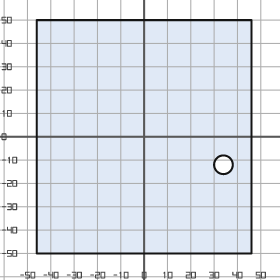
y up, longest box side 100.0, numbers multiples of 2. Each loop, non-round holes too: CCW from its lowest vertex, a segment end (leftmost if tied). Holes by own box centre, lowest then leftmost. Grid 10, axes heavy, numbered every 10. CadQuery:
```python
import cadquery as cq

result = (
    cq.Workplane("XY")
    .moveTo(-46.0, -50.0)
    .lineTo(46.0, -50.0)
    .lineTo(46.0, 50.0)
    .lineTo(-46.0, 50.0)
    .close()
    .moveTo(34.0, -12.0)
    .circle(4.0)
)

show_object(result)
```